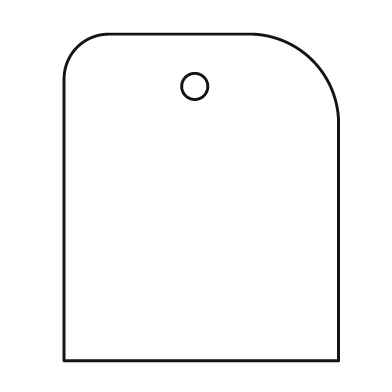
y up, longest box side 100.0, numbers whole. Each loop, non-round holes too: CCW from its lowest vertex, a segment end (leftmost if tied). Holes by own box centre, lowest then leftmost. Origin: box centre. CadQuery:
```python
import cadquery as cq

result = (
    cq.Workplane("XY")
    .moveTo(-42.0, -50.0)
    .lineTo(42.0, -50.0)
    .lineTo(42.0, 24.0)
    .threePointArc((34.0, 42.0), (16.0, 50.0))
    .lineTo(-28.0, 50.0)
    .threePointArc((-38.0, 46.0), (-42.0, 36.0))
    .close()
    .moveTo(-2.0, 34.0)
    .circle(4.0)
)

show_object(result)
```